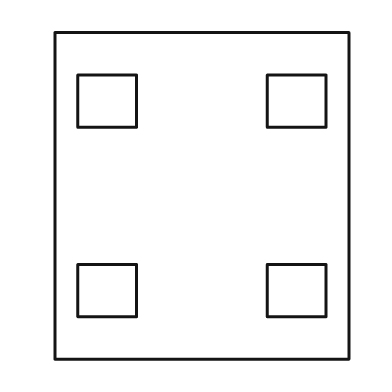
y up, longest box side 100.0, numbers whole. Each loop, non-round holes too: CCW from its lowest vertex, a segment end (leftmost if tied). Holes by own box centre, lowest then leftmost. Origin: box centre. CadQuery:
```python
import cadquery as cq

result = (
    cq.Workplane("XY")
    .moveTo(-45.0, -50.0)
    .lineTo(45.0, -50.0)
    .lineTo(45.0, 50.0)
    .lineTo(-45.0, 50.0)
    .close()
    .moveTo(-38.0, -37.0)
    .lineTo(-20.0, -37.0)
    .lineTo(-20.0, -21.0)
    .lineTo(-38.0, -21.0)
    .close()
    .moveTo(20.0, -37.0)
    .lineTo(38.0, -37.0)
    .lineTo(38.0, -21.0)
    .lineTo(20.0, -21.0)
    .close()
    .moveTo(-38.0, 21.0)
    .lineTo(-20.0, 21.0)
    .lineTo(-20.0, 37.0)
    .lineTo(-38.0, 37.0)
    .close()
    .moveTo(20.0, 21.0)
    .lineTo(38.0, 21.0)
    .lineTo(38.0, 37.0)
    .lineTo(20.0, 37.0)
    .close()
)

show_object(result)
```